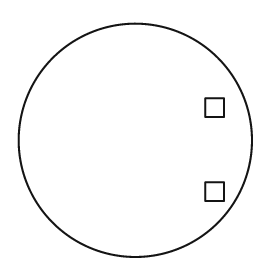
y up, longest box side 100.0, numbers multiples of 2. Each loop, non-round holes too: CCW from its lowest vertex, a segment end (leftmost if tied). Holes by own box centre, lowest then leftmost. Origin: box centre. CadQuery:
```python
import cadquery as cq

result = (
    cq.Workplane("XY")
    .moveTo(0.0, 0.0)
    .circle(50.0)
    .moveTo(30.0, -26.0)
    .lineTo(38.0, -26.0)
    .lineTo(38.0, -18.0)
    .lineTo(30.0, -18.0)
    .close()
    .moveTo(30.0, 10.0)
    .lineTo(38.0, 10.0)
    .lineTo(38.0, 18.0)
    .lineTo(30.0, 18.0)
    .close()
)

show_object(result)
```